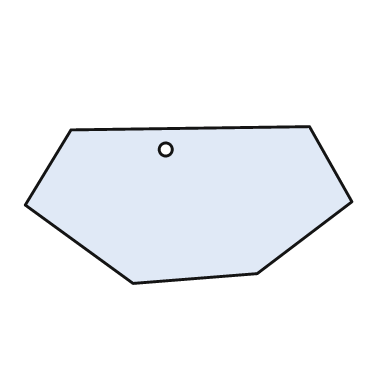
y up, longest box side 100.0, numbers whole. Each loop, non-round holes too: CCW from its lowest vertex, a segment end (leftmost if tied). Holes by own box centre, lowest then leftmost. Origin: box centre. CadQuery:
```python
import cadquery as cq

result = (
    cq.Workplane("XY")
    .moveTo(-17.0, -24.0)
    .lineTo(21.0, -21.0)
    .lineTo(50.0, 1.0)
    .lineTo(37.0, 24.0)
    .lineTo(-36.0, 23.0)
    .lineTo(-50.0, 0.0)
    .close()
    .moveTo(-7.0, 17.0)
    .circle(2.0)
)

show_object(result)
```